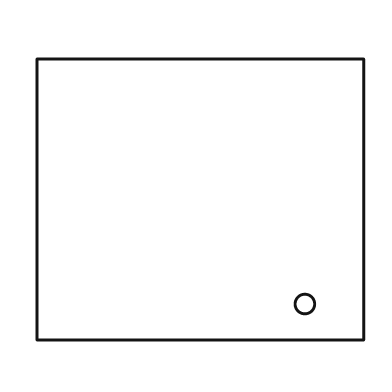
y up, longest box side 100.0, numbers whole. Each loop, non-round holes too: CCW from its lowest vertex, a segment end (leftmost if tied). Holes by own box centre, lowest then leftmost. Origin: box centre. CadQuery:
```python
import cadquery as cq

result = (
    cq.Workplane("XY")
    .moveTo(-50.0, -43.0)
    .lineTo(50.0, -43.0)
    .lineTo(50.0, 43.0)
    .lineTo(-50.0, 43.0)
    .close()
    .moveTo(32.0, -32.0)
    .circle(3.0)
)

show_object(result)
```